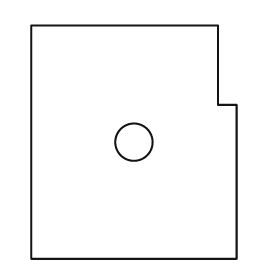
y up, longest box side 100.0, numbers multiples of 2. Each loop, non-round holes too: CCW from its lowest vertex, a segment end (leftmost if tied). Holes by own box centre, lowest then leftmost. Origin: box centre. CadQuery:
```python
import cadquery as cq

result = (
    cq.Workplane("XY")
    .moveTo(-44.0, -50.0)
    .lineTo(44.0, -50.0)
    .lineTo(44.0, 16.0)
    .lineTo(36.0, 16.0)
    .lineTo(36.0, 50.0)
    .lineTo(-44.0, 50.0)
    .close()
    .moveTo(0.0, 0.0)
    .circle(8.0)
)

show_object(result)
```